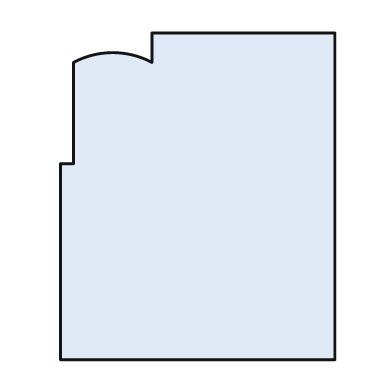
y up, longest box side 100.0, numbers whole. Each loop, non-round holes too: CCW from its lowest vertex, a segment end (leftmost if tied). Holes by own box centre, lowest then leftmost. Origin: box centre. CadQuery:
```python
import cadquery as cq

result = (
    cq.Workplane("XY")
    .moveTo(-42.0, -50.0)
    .lineTo(42.0, -50.0)
    .lineTo(42.0, 50.0)
    .lineTo(-14.0, 50.0)
    .lineTo(-14.0, 41.0)
    .threePointArc((-26.0, 44.0), (-38.0, 41.0))
    .lineTo(-38.0, 10.0)
    .lineTo(-42.0, 10.0)
    .close()
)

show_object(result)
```